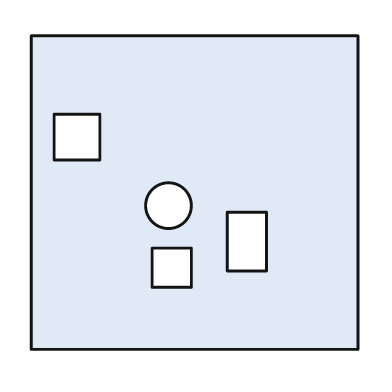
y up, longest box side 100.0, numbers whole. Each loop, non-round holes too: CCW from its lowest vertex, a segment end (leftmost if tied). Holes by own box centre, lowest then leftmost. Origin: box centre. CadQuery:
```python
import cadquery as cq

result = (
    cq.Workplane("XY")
    .moveTo(-50.0, -48.0)
    .lineTo(50.0, -48.0)
    .lineTo(50.0, 48.0)
    .lineTo(-50.0, 48.0)
    .close()
    .moveTo(-13.0, -29.0)
    .lineTo(-1.0, -29.0)
    .lineTo(-1.0, -17.0)
    .lineTo(-13.0, -17.0)
    .close()
    .moveTo(10.0, -24.0)
    .lineTo(22.0, -24.0)
    .lineTo(22.0, -6.0)
    .lineTo(10.0, -6.0)
    .close()
    .moveTo(-8.0, -4.0)
    .circle(7.0)
    .moveTo(-43.0, 10.0)
    .lineTo(-29.0, 10.0)
    .lineTo(-29.0, 24.0)
    .lineTo(-43.0, 24.0)
    .close()
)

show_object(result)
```